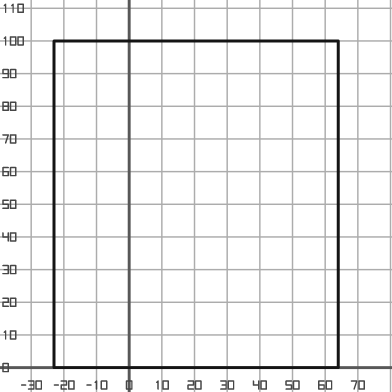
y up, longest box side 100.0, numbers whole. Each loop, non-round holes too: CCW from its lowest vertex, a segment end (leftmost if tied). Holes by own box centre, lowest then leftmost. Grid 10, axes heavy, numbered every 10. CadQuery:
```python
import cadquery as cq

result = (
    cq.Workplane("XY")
    .moveTo(-23.0, 0.0)
    .lineTo(64.0, 0.0)
    .lineTo(64.0, 100.0)
    .lineTo(-23.0, 100.0)
    .close()
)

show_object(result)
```